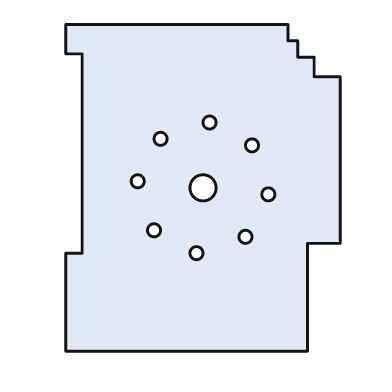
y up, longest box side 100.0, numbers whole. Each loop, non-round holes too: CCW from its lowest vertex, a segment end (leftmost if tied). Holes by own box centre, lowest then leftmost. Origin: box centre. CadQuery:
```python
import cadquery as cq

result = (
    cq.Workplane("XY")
    .moveTo(-42.0, -50.0)
    .lineTo(32.0, -50.0)
    .lineTo(32.0, -17.0)
    .lineTo(42.0, -17.0)
    .lineTo(42.0, 34.0)
    .lineTo(34.0, 34.0)
    .lineTo(34.0, 40.0)
    .lineTo(29.0, 40.0)
    .lineTo(29.0, 45.0)
    .lineTo(26.0, 45.0)
    .lineTo(26.0, 50.0)
    .lineTo(-42.0, 50.0)
    .lineTo(-42.0, 41.0)
    .lineTo(-37.0, 41.0)
    .lineTo(-37.0, -20.0)
    .lineTo(-42.0, -20.0)
    .close()
    .moveTo(-2.0, -20.0)
    .circle(2.0)
    .moveTo(13.0, -15.0)
    .circle(2.0)
    .moveTo(-15.0, -13.0)
    .circle(2.0)
    .moveTo(20.0, -2.0)
    .circle(2.0)
    .moveTo(0.0, 0.0)
    .circle(4.0)
    .moveTo(-20.0, 2.0)
    .circle(2.0)
    .moveTo(15.0, 13.0)
    .circle(2.0)
    .moveTo(-13.0, 15.0)
    .circle(2.0)
    .moveTo(2.0, 20.0)
    .circle(2.0)
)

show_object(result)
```